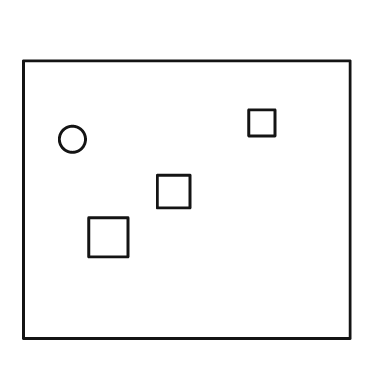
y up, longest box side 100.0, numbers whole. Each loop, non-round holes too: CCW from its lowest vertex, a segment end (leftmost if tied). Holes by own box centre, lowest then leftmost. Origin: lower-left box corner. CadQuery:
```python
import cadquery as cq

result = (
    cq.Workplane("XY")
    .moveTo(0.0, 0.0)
    .lineTo(100.0, 0.0)
    .lineTo(100.0, 85.0)
    .lineTo(0.0, 85.0)
    .close()
    .moveTo(20.0, 25.0)
    .lineTo(32.0, 25.0)
    .lineTo(32.0, 37.0)
    .lineTo(20.0, 37.0)
    .close()
    .moveTo(41.0, 40.0)
    .lineTo(51.0, 40.0)
    .lineTo(51.0, 50.0)
    .lineTo(41.0, 50.0)
    .close()
    .moveTo(15.0, 61.0)
    .circle(4.0)
    .moveTo(69.0, 62.0)
    .lineTo(77.0, 62.0)
    .lineTo(77.0, 70.0)
    .lineTo(69.0, 70.0)
    .close()
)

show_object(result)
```